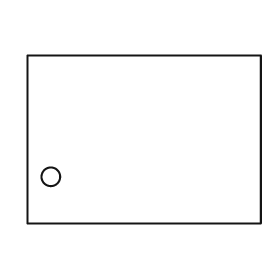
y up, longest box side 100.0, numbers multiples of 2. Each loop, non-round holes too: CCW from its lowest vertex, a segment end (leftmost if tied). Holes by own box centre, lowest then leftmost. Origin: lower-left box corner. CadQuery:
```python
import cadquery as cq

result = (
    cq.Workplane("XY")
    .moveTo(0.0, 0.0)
    .lineTo(100.0, 0.0)
    .lineTo(100.0, 72.0)
    .lineTo(0.0, 72.0)
    .close()
    .moveTo(10.0, 20.0)
    .circle(4.0)
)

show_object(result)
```